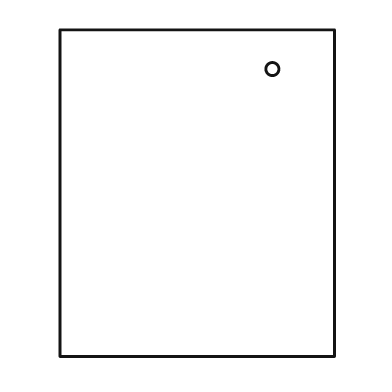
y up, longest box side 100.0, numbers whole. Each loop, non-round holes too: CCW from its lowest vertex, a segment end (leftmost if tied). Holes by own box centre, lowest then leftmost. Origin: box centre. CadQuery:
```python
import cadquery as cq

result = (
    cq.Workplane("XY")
    .moveTo(-42.0, -50.0)
    .lineTo(42.0, -50.0)
    .lineTo(42.0, 50.0)
    .lineTo(-42.0, 50.0)
    .close()
    .moveTo(23.0, 38.0)
    .circle(2.0)
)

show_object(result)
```